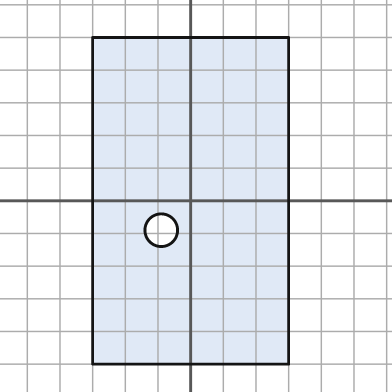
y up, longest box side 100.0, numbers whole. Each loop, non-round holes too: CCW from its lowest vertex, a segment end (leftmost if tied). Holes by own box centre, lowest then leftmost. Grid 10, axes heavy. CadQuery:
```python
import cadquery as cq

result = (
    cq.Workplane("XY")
    .moveTo(-30.0, -50.0)
    .lineTo(30.0, -50.0)
    .lineTo(30.0, 50.0)
    .lineTo(-30.0, 50.0)
    .close()
    .moveTo(-9.0, -9.0)
    .circle(5.0)
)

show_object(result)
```